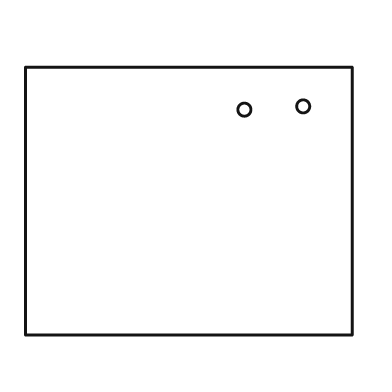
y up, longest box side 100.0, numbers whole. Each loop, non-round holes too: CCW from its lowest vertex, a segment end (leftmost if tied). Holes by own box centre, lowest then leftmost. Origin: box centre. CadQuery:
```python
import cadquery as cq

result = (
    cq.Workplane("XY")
    .moveTo(-50.0, -41.0)
    .lineTo(50.0, -41.0)
    .lineTo(50.0, 41.0)
    .lineTo(-50.0, 41.0)
    .close()
    .moveTo(17.0, 28.0)
    .circle(2.0)
    .moveTo(35.0, 29.0)
    .circle(2.0)
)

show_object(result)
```